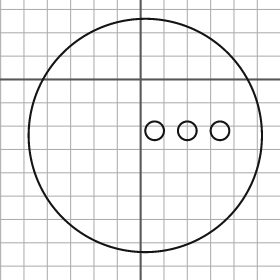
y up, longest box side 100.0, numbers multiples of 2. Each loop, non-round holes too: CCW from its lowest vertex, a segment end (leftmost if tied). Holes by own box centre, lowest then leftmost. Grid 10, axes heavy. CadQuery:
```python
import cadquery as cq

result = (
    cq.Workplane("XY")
    .moveTo(2.0, -24.0)
    .circle(50.0)
    .moveTo(6.0, -22.0)
    .circle(4.0)
    .moveTo(20.0, -22.0)
    .circle(4.0)
    .moveTo(34.0, -22.0)
    .circle(4.0)
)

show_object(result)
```